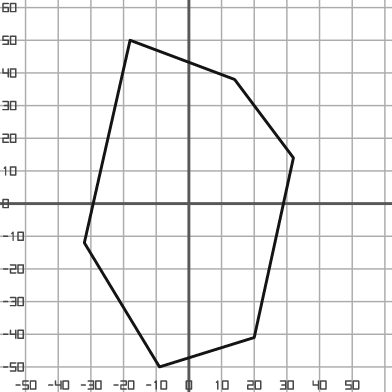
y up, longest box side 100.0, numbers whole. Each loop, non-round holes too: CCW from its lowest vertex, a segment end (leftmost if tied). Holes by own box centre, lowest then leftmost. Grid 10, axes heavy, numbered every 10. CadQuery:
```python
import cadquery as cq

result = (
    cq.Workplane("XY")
    .moveTo(-9.0, -50.0)
    .lineTo(20.0, -41.0)
    .lineTo(32.0, 14.0)
    .lineTo(14.0, 38.0)
    .lineTo(-18.0, 50.0)
    .lineTo(-32.0, -12.0)
    .close()
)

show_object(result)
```